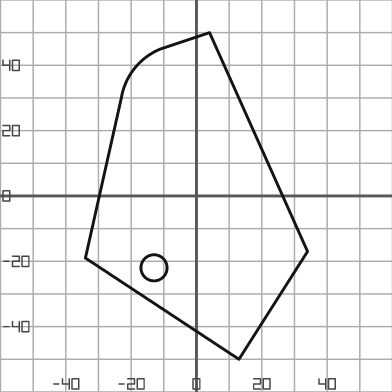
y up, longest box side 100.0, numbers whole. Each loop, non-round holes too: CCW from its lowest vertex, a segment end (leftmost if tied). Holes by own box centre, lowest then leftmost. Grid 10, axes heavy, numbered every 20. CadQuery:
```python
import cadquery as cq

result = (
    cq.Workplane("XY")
    .moveTo(13.0, -50.0)
    .lineTo(34.0, -17.0)
    .lineTo(4.0, 50.0)
    .lineTo(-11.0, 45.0)
    .threePointArc((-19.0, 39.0), (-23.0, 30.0))
    .lineTo(-34.0, -19.0)
    .close()
    .moveTo(-13.0, -22.0)
    .circle(4.0)
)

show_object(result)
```